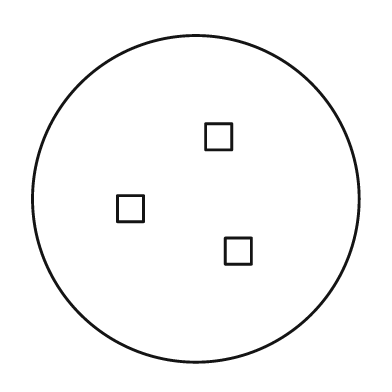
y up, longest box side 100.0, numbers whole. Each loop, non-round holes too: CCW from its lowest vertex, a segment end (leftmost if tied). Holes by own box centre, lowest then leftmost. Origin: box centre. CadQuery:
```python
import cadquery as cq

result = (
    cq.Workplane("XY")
    .moveTo(0.0, 0.0)
    .circle(50.0)
    .moveTo(9.0, -20.0)
    .lineTo(17.0, -20.0)
    .lineTo(17.0, -12.0)
    .lineTo(9.0, -12.0)
    .close()
    .moveTo(-24.0, -7.0)
    .lineTo(-16.0, -7.0)
    .lineTo(-16.0, 1.0)
    .lineTo(-24.0, 1.0)
    .close()
    .moveTo(3.0, 15.0)
    .lineTo(11.0, 15.0)
    .lineTo(11.0, 23.0)
    .lineTo(3.0, 23.0)
    .close()
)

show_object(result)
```